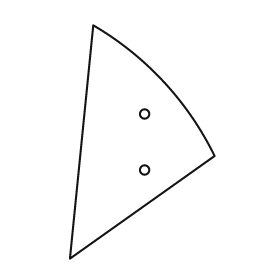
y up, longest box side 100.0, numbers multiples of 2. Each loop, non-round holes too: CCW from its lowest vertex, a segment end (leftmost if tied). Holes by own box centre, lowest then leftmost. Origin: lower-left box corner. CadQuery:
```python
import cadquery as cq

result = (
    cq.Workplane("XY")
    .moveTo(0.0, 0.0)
    .lineTo(62.0, 44.0)
    .threePointArc((40.0, 76.0), (10.0, 100.0))
    .close()
    .moveTo(32.0, 38.0)
    .circle(2.0)
    .moveTo(32.0, 62.0)
    .circle(2.0)
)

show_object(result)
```